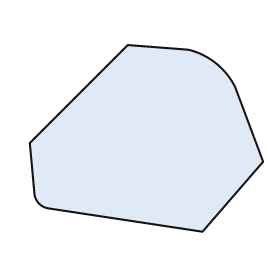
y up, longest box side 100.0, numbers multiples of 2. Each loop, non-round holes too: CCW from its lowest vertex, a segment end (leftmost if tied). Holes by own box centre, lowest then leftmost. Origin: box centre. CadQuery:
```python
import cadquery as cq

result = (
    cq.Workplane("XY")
    .moveTo(24.0, -40.0)
    .lineTo(50.0, -10.0)
    .lineTo(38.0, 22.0)
    .threePointArc((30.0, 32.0), (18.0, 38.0))
    .lineTo(-8.0, 40.0)
    .lineTo(-50.0, -2.0)
    .lineTo(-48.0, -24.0)
    .threePointArc((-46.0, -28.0), (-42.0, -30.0))
    .close()
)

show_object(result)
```